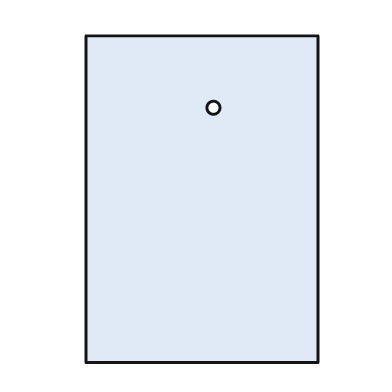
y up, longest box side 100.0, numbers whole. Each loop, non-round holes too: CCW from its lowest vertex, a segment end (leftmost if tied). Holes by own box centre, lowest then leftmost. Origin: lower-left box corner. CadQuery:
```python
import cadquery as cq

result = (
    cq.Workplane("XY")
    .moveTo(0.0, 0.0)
    .lineTo(71.0, 0.0)
    .lineTo(71.0, 100.0)
    .lineTo(0.0, 100.0)
    .close()
    .moveTo(39.0, 78.0)
    .circle(2.0)
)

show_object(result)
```